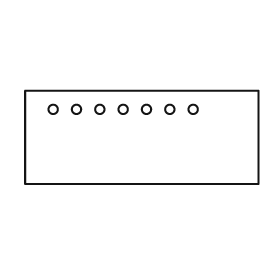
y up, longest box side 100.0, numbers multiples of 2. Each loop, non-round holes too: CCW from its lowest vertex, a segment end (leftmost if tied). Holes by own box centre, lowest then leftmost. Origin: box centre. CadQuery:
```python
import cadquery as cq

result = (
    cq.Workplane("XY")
    .moveTo(-50.0, -20.0)
    .lineTo(50.0, -20.0)
    .lineTo(50.0, 20.0)
    .lineTo(-50.0, 20.0)
    .close()
    .moveTo(-38.0, 12.0)
    .circle(2.0)
    .moveTo(-28.0, 12.0)
    .circle(2.0)
    .moveTo(-18.0, 12.0)
    .circle(2.0)
    .moveTo(-8.0, 12.0)
    .circle(2.0)
    .moveTo(2.0, 12.0)
    .circle(2.0)
    .moveTo(12.0, 12.0)
    .circle(2.0)
    .moveTo(22.0, 12.0)
    .circle(2.0)
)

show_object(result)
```